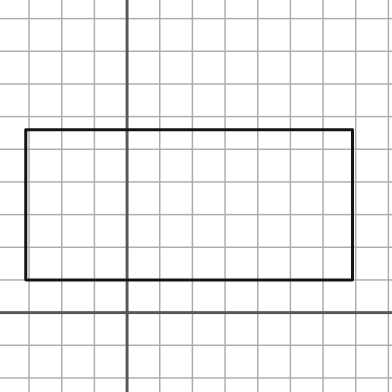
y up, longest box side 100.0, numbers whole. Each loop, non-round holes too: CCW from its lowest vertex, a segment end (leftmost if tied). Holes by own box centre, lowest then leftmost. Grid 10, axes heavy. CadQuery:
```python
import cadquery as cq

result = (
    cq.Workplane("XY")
    .moveTo(-31.0, 10.0)
    .lineTo(69.0, 10.0)
    .lineTo(69.0, 56.0)
    .lineTo(-31.0, 56.0)
    .close()
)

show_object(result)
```